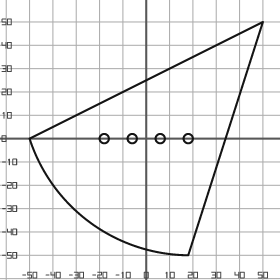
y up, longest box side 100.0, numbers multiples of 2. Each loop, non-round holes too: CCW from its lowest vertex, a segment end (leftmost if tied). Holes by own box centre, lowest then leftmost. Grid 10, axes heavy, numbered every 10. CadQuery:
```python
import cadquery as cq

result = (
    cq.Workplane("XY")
    .moveTo(18.0, -50.0)
    .lineTo(50.0, 50.0)
    .lineTo(-50.0, 0.0)
    .threePointArc((-24.0, -36.0), (18.0, -50.0))
    .close()
    .moveTo(-18.0, 0.0)
    .circle(2.0)
    .moveTo(-6.0, 0.0)
    .circle(2.0)
    .moveTo(6.0, 0.0)
    .circle(2.0)
    .moveTo(18.0, 0.0)
    .circle(2.0)
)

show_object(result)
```